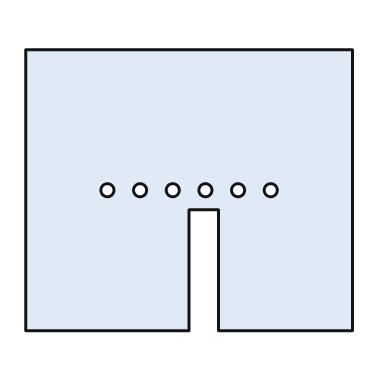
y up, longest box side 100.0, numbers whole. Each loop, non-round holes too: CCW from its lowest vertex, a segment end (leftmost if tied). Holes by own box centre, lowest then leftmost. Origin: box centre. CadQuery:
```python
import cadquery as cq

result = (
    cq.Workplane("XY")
    .moveTo(-50.0, -43.0)
    .lineTo(0.0, -43.0)
    .lineTo(0.0, -6.0)
    .lineTo(9.0, -6.0)
    .lineTo(9.0, -43.0)
    .lineTo(50.0, -43.0)
    .lineTo(50.0, 43.0)
    .lineTo(-50.0, 43.0)
    .close()
    .moveTo(-25.0, 0.0)
    .circle(2.0)
    .moveTo(-15.0, 0.0)
    .circle(2.0)
    .moveTo(-5.0, 0.0)
    .circle(2.0)
    .moveTo(5.0, 0.0)
    .circle(2.0)
    .moveTo(15.0, 0.0)
    .circle(2.0)
    .moveTo(25.0, 0.0)
    .circle(2.0)
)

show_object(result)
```